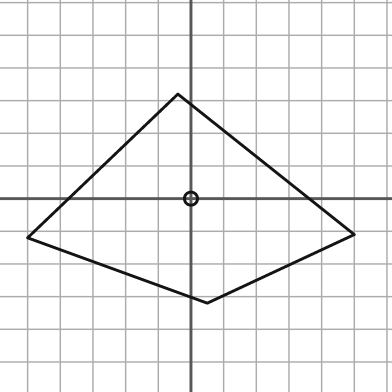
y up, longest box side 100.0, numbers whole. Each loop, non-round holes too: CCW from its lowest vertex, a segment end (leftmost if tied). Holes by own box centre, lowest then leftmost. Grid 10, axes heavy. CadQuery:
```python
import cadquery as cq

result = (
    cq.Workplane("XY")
    .moveTo(5.0, -32.0)
    .lineTo(50.0, -11.0)
    .lineTo(-4.0, 32.0)
    .lineTo(-50.0, -12.0)
    .close()
    .moveTo(0.0, 0.0)
    .circle(2.0)
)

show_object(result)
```